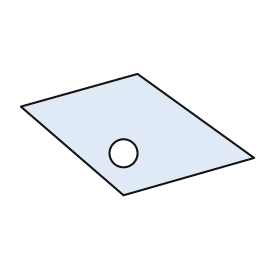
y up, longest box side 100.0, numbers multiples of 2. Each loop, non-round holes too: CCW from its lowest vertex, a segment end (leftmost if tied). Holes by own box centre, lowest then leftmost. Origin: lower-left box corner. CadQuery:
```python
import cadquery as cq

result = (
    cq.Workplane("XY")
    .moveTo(44.0, 0.0)
    .lineTo(100.0, 16.0)
    .lineTo(50.0, 52.0)
    .lineTo(0.0, 38.0)
    .close()
    .moveTo(44.0, 18.0)
    .circle(6.0)
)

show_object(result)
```